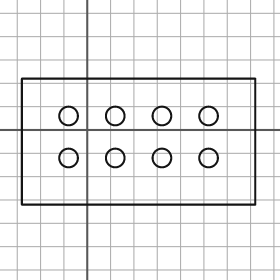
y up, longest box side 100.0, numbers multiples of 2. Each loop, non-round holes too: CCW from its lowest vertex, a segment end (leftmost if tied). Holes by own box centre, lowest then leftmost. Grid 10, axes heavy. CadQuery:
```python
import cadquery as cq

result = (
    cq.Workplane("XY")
    .moveTo(-28.0, -32.0)
    .lineTo(72.0, -32.0)
    .lineTo(72.0, 22.0)
    .lineTo(-28.0, 22.0)
    .close()
    .moveTo(-8.0, -12.0)
    .circle(4.0)
    .moveTo(12.0, -12.0)
    .circle(4.0)
    .moveTo(32.0, -12.0)
    .circle(4.0)
    .moveTo(52.0, -12.0)
    .circle(4.0)
    .moveTo(-8.0, 6.0)
    .circle(4.0)
    .moveTo(12.0, 6.0)
    .circle(4.0)
    .moveTo(32.0, 6.0)
    .circle(4.0)
    .moveTo(52.0, 6.0)
    .circle(4.0)
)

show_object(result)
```